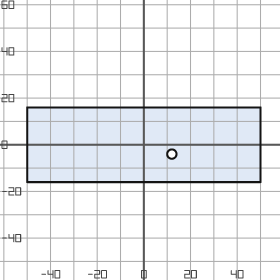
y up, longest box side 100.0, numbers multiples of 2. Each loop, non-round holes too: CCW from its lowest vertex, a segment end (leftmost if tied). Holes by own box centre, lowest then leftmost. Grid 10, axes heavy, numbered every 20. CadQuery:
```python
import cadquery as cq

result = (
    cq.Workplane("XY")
    .moveTo(-50.0, -16.0)
    .lineTo(50.0, -16.0)
    .lineTo(50.0, 16.0)
    .lineTo(-50.0, 16.0)
    .close()
    .moveTo(12.0, -4.0)
    .circle(2.0)
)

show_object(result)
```